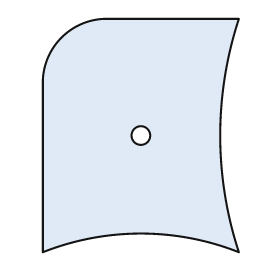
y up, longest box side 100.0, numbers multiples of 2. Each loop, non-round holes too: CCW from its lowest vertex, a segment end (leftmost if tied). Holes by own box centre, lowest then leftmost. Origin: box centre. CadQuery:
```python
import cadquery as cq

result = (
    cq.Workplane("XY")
    .moveTo(-42.0, -50.0)
    .threePointArc((0.0, -42.0), (42.0, -50.0))
    .threePointArc((34.0, 0.0), (42.0, 50.0))
    .lineTo(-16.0, 50.0)
    .threePointArc((-34.0, 42.0), (-42.0, 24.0))
    .close()
    .moveTo(0.0, 0.0)
    .circle(4.0)
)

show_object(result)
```